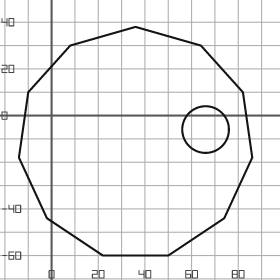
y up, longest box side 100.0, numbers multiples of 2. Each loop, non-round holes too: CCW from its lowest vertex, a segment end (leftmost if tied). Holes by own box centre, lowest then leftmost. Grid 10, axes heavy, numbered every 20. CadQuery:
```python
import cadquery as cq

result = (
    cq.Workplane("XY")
    .moveTo(22.0, -60.0)
    .lineTo(50.0, -60.0)
    .lineTo(74.0, -44.0)
    .lineTo(86.0, -18.0)
    .lineTo(82.0, 10.0)
    .lineTo(64.0, 30.0)
    .lineTo(36.0, 38.0)
    .lineTo(8.0, 30.0)
    .lineTo(-10.0, 10.0)
    .lineTo(-14.0, -18.0)
    .lineTo(-2.0, -44.0)
    .close()
    .moveTo(66.0, -6.0)
    .circle(10.0)
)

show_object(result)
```